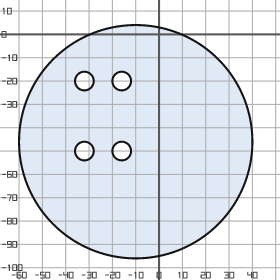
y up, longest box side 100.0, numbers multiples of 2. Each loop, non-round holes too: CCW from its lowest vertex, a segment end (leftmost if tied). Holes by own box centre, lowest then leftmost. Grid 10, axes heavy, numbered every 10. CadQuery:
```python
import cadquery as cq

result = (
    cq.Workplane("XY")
    .moveTo(-10.0, -46.0)
    .circle(50.0)
    .moveTo(-32.0, -50.0)
    .circle(4.0)
    .moveTo(-16.0, -50.0)
    .circle(4.0)
    .moveTo(-32.0, -20.0)
    .circle(4.0)
    .moveTo(-16.0, -20.0)
    .circle(4.0)
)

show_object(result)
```